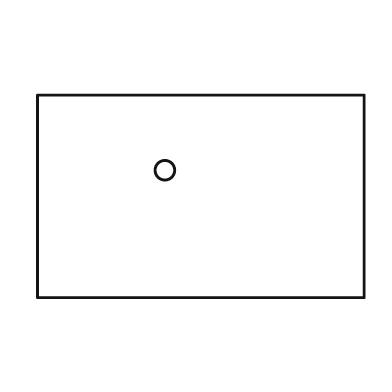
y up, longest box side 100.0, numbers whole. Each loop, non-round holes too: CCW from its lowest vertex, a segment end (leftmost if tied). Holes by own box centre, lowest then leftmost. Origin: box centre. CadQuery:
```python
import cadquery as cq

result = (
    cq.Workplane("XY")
    .moveTo(-50.0, -31.0)
    .lineTo(50.0, -31.0)
    .lineTo(50.0, 31.0)
    .lineTo(-50.0, 31.0)
    .close()
    .moveTo(-11.0, 8.0)
    .circle(3.0)
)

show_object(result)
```